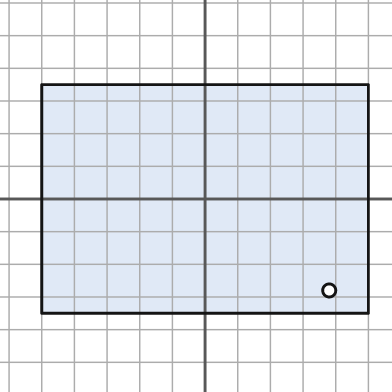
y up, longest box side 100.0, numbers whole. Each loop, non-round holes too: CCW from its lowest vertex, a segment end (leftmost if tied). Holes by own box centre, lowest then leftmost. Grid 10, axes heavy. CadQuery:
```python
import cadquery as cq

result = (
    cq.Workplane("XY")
    .moveTo(-50.0, -35.0)
    .lineTo(50.0, -35.0)
    .lineTo(50.0, 35.0)
    .lineTo(-50.0, 35.0)
    .close()
    .moveTo(38.0, -28.0)
    .circle(2.0)
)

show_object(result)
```